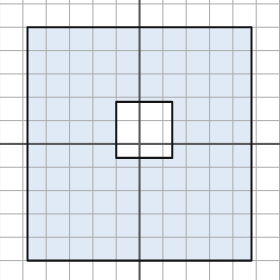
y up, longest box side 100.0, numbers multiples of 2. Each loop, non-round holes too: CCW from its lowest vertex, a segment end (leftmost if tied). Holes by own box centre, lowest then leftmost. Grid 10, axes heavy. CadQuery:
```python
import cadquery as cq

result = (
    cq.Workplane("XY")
    .moveTo(-48.0, -50.0)
    .lineTo(48.0, -50.0)
    .lineTo(48.0, 50.0)
    .lineTo(-48.0, 50.0)
    .close()
    .moveTo(-10.0, -6.0)
    .lineTo(14.0, -6.0)
    .lineTo(14.0, 18.0)
    .lineTo(-10.0, 18.0)
    .close()
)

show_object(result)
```